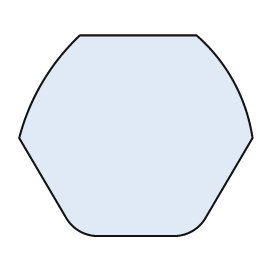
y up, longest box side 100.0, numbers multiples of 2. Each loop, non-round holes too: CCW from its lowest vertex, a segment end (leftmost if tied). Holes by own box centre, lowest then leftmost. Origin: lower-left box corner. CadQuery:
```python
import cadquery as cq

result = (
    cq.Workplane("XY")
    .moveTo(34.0, 0.0)
    .lineTo(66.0, 0.0)
    .threePointArc((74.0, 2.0), (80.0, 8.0))
    .lineTo(100.0, 42.0)
    .threePointArc((92.0, 66.0), (76.0, 86.0))
    .lineTo(26.0, 86.0)
    .threePointArc((10.0, 66.0), (0.0, 42.0))
    .lineTo(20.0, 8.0)
    .threePointArc((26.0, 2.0), (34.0, 0.0))
    .close()
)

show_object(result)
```